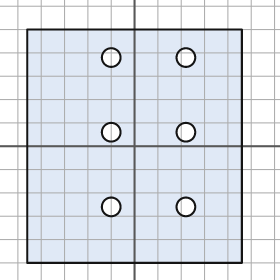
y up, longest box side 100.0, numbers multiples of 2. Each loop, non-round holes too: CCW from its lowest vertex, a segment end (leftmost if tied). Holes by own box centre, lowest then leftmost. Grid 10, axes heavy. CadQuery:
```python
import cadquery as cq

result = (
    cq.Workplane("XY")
    .moveTo(-46.0, -50.0)
    .lineTo(46.0, -50.0)
    .lineTo(46.0, 50.0)
    .lineTo(-46.0, 50.0)
    .close()
    .moveTo(-10.0, -26.0)
    .circle(4.0)
    .moveTo(22.0, -26.0)
    .circle(4.0)
    .moveTo(-10.0, 6.0)
    .circle(4.0)
    .moveTo(22.0, 6.0)
    .circle(4.0)
    .moveTo(-10.0, 38.0)
    .circle(4.0)
    .moveTo(22.0, 38.0)
    .circle(4.0)
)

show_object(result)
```